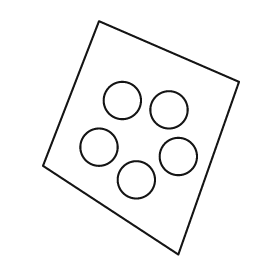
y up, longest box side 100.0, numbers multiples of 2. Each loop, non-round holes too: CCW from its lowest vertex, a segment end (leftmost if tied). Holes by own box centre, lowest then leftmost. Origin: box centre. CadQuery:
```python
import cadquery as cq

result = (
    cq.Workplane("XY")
    .moveTo(16.0, -50.0)
    .lineTo(42.0, 24.0)
    .lineTo(-18.0, 50.0)
    .lineTo(-42.0, -12.0)
    .close()
    .moveTo(-2.0, -18.0)
    .circle(8.0)
    .moveTo(16.0, -8.0)
    .circle(8.0)
    .moveTo(-18.0, -4.0)
    .circle(8.0)
    .moveTo(12.0, 12.0)
    .circle(8.0)
    .moveTo(-8.0, 16.0)
    .circle(8.0)
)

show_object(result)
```